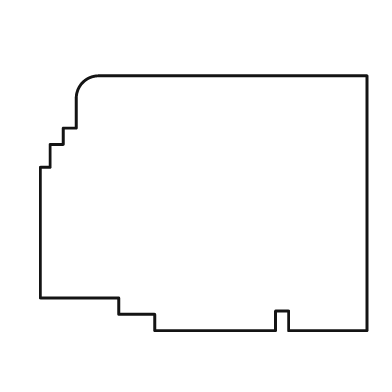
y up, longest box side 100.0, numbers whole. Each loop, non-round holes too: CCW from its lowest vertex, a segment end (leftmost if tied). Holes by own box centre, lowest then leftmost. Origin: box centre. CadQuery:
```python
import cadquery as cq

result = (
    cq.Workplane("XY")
    .moveTo(-15.0, -39.0)
    .lineTo(22.0, -39.0)
    .lineTo(22.0, -33.0)
    .lineTo(26.0, -33.0)
    .lineTo(26.0, -39.0)
    .lineTo(50.0, -39.0)
    .lineTo(50.0, 39.0)
    .lineTo(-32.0, 39.0)
    .threePointArc((-37.0, 37.0), (-39.0, 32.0))
    .lineTo(-39.0, 23.0)
    .lineTo(-43.0, 23.0)
    .lineTo(-43.0, 18.0)
    .lineTo(-47.0, 18.0)
    .lineTo(-47.0, 11.0)
    .lineTo(-50.0, 11.0)
    .lineTo(-50.0, -29.0)
    .lineTo(-26.0, -29.0)
    .lineTo(-26.0, -34.0)
    .lineTo(-15.0, -34.0)
    .close()
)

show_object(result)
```